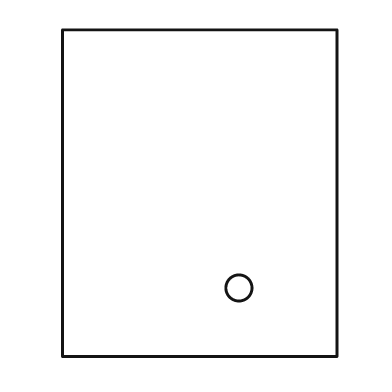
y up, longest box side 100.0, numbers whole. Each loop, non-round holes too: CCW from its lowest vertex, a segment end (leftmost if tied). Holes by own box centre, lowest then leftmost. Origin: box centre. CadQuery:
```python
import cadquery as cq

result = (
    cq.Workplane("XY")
    .moveTo(-42.0, -50.0)
    .lineTo(42.0, -50.0)
    .lineTo(42.0, 50.0)
    .lineTo(-42.0, 50.0)
    .close()
    .moveTo(12.0, -29.0)
    .circle(4.0)
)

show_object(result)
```